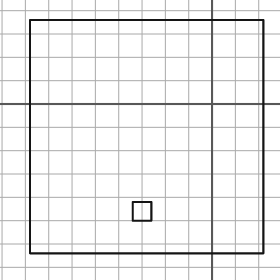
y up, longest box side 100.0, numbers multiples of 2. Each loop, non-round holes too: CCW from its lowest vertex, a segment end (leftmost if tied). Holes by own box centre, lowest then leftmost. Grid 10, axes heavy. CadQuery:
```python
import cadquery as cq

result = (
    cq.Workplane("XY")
    .moveTo(-78.0, -64.0)
    .lineTo(22.0, -64.0)
    .lineTo(22.0, 36.0)
    .lineTo(-78.0, 36.0)
    .close()
    .moveTo(-34.0, -50.0)
    .lineTo(-26.0, -50.0)
    .lineTo(-26.0, -42.0)
    .lineTo(-34.0, -42.0)
    .close()
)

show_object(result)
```